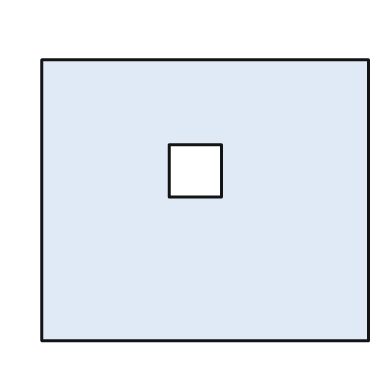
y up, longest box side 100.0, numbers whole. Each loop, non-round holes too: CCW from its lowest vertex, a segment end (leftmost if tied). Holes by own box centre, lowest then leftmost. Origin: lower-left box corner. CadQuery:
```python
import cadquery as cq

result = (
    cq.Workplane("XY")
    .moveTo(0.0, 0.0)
    .lineTo(100.0, 0.0)
    .lineTo(100.0, 86.0)
    .lineTo(0.0, 86.0)
    .close()
    .moveTo(39.0, 44.0)
    .lineTo(55.0, 44.0)
    .lineTo(55.0, 60.0)
    .lineTo(39.0, 60.0)
    .close()
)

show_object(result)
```